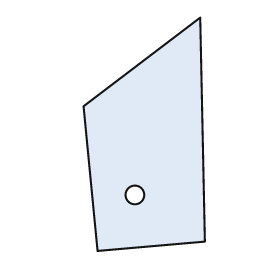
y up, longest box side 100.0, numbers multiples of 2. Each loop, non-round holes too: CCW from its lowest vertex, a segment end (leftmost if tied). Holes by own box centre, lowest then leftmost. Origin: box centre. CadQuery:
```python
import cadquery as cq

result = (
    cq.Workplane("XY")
    .moveTo(-20.0, -50.0)
    .lineTo(26.0, -46.0)
    .lineTo(24.0, 50.0)
    .lineTo(-26.0, 12.0)
    .close()
    .moveTo(-4.0, -26.0)
    .circle(4.0)
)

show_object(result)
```